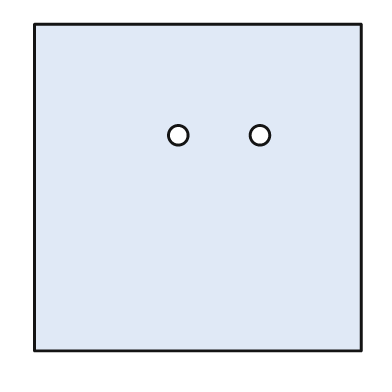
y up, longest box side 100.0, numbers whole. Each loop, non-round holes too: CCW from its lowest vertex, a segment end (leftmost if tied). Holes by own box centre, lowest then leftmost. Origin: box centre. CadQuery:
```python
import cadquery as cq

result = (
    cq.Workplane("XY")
    .moveTo(-50.0, -50.0)
    .lineTo(50.0, -50.0)
    .lineTo(50.0, 50.0)
    .lineTo(-50.0, 50.0)
    .close()
    .moveTo(-6.0, 16.0)
    .circle(3.0)
    .moveTo(19.0, 16.0)
    .circle(3.0)
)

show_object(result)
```